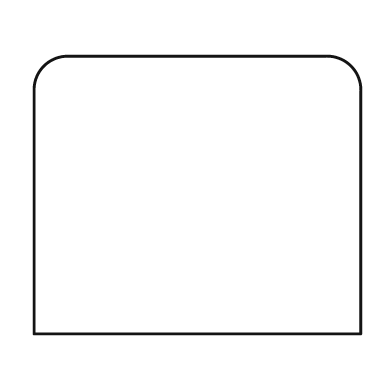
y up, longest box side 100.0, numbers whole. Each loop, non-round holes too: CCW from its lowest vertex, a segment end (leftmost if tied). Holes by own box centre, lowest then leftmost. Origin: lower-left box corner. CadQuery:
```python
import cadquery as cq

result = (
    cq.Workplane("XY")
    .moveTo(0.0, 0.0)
    .lineTo(100.0, 0.0)
    .lineTo(100.0, 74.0)
    .threePointArc((97.0, 82.0), (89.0, 85.0))
    .lineTo(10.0, 85.0)
    .threePointArc((3.0, 82.0), (0.0, 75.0))
    .close()
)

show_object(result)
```